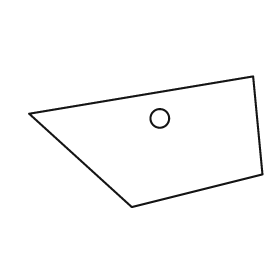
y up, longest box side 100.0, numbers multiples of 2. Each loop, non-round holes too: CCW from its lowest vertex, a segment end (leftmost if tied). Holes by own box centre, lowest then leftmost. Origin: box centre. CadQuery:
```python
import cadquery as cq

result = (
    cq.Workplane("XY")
    .moveTo(-6.0, -28.0)
    .lineTo(50.0, -14.0)
    .lineTo(46.0, 28.0)
    .lineTo(-50.0, 12.0)
    .close()
    .moveTo(6.0, 10.0)
    .circle(4.0)
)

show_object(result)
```